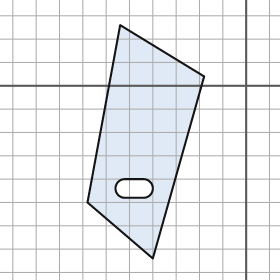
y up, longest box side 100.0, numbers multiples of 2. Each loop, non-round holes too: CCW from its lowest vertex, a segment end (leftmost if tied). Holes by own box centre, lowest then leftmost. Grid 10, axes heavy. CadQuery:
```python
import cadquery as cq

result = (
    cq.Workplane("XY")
    .moveTo(-40.0, -74.0)
    .lineTo(-18.0, 4.0)
    .lineTo(-54.0, 26.0)
    .lineTo(-68.0, -50.0)
    .close()
    .moveTo(-52.0, -48.0)
    .lineTo(-44.0, -48.0)
    .threePointArc((-40.0, -44.0), (-44.0, -40.0))
    .lineTo(-52.0, -40.0)
    .threePointArc((-56.0, -44.0), (-52.0, -48.0))
    .close()
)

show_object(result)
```